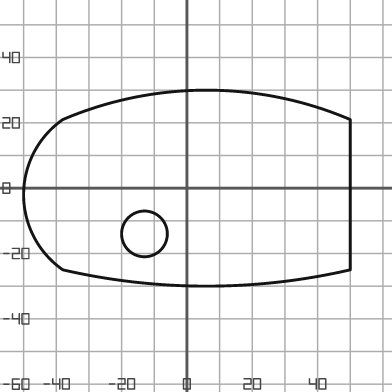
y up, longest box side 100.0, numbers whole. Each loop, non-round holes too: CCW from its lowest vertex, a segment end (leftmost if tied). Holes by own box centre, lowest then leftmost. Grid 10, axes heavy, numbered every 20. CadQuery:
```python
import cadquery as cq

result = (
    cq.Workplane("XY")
    .moveTo(-38.0, -25.0)
    .threePointArc((6.0, -30.0), (50.0, -25.0))
    .lineTo(50.0, 21.0)
    .threePointArc((6.0, 30.0), (-38.0, 21.0))
    .threePointArc((-50.0, -2.0), (-38.0, -25.0))
    .close()
    .moveTo(-13.0, -14.0)
    .circle(7.0)
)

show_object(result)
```